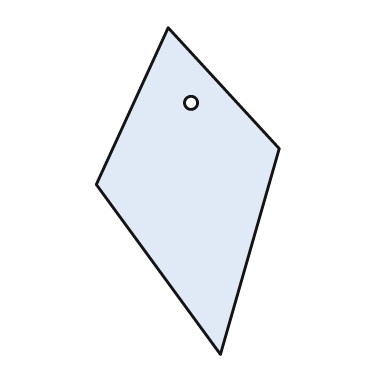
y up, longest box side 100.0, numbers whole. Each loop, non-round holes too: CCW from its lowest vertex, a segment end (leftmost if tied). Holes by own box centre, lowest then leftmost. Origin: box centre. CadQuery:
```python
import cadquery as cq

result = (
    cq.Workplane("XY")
    .moveTo(10.0, -50.0)
    .lineTo(28.0, 13.0)
    .lineTo(-6.0, 50.0)
    .lineTo(-28.0, 2.0)
    .close()
    .moveTo(1.0, 27.0)
    .circle(2.0)
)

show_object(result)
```